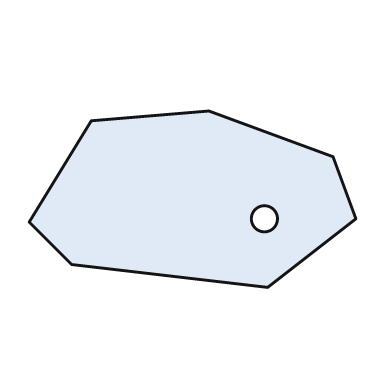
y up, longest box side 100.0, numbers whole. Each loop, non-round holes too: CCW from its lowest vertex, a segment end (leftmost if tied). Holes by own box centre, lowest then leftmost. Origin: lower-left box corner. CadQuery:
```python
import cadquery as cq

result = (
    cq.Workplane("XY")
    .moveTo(73.0, 0.0)
    .lineTo(100.0, 21.0)
    .lineTo(93.0, 40.0)
    .lineTo(55.0, 54.0)
    .lineTo(19.0, 51.0)
    .lineTo(0.0, 20.0)
    .lineTo(13.0, 7.0)
    .close()
    .moveTo(72.0, 21.0)
    .circle(4.0)
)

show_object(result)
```